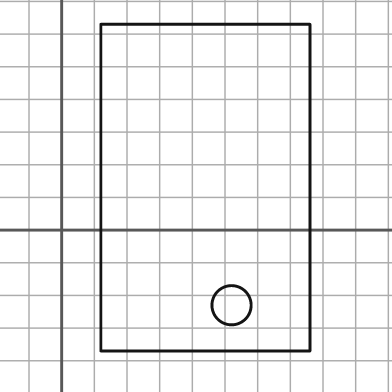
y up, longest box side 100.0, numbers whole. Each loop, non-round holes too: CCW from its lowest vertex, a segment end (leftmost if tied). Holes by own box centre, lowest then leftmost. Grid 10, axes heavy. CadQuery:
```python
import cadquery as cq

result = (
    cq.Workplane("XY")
    .moveTo(12.0, -37.0)
    .lineTo(76.0, -37.0)
    .lineTo(76.0, 63.0)
    .lineTo(12.0, 63.0)
    .close()
    .moveTo(52.0, -23.0)
    .circle(6.0)
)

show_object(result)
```